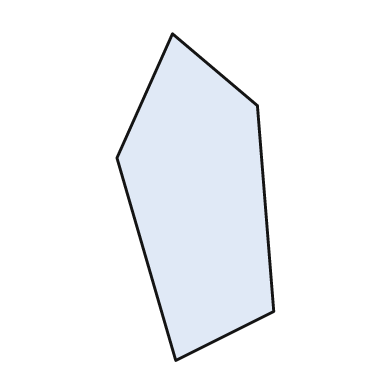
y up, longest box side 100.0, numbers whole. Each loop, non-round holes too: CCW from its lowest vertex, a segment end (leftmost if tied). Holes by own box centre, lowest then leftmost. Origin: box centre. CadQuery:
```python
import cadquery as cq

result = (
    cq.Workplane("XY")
    .moveTo(-6.0, -50.0)
    .lineTo(24.0, -35.0)
    .lineTo(19.0, 28.0)
    .lineTo(-7.0, 50.0)
    .lineTo(-24.0, 12.0)
    .close()
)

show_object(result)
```